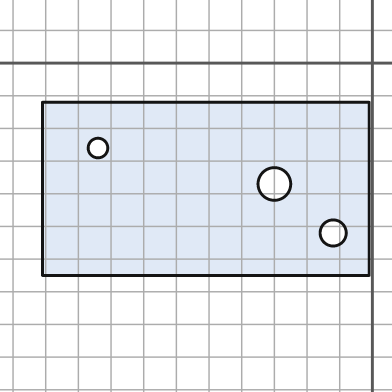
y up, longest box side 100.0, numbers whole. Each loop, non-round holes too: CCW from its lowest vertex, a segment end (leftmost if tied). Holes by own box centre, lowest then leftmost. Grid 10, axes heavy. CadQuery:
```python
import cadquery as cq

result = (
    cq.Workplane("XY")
    .moveTo(-101.0, -65.0)
    .lineTo(-1.0, -65.0)
    .lineTo(-1.0, -12.0)
    .lineTo(-101.0, -12.0)
    .close()
    .moveTo(-12.0, -52.0)
    .circle(4.0)
    .moveTo(-30.0, -37.0)
    .circle(5.0)
    .moveTo(-84.0, -26.0)
    .circle(3.0)
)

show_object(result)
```